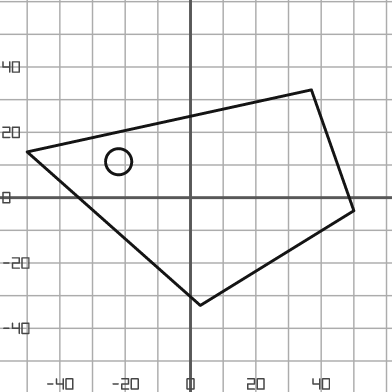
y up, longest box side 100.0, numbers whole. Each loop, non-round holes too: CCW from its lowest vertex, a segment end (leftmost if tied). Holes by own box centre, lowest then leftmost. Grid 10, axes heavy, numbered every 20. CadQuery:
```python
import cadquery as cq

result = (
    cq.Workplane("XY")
    .moveTo(3.0, -33.0)
    .lineTo(50.0, -4.0)
    .lineTo(37.0, 33.0)
    .lineTo(-50.0, 14.0)
    .close()
    .moveTo(-22.0, 11.0)
    .circle(4.0)
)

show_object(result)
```